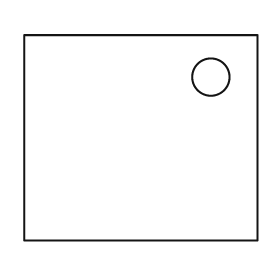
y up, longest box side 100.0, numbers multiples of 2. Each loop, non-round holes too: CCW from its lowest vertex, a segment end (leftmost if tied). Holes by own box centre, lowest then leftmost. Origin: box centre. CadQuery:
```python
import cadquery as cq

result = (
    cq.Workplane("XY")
    .moveTo(-50.0, -44.0)
    .lineTo(50.0, -44.0)
    .lineTo(50.0, 44.0)
    .lineTo(-50.0, 44.0)
    .close()
    .moveTo(30.0, 26.0)
    .circle(8.0)
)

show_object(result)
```